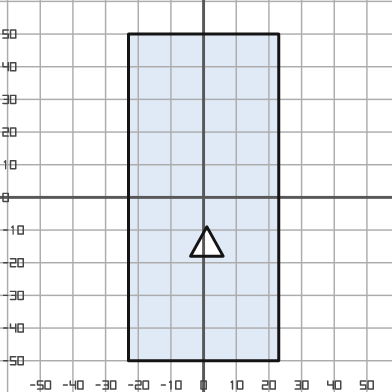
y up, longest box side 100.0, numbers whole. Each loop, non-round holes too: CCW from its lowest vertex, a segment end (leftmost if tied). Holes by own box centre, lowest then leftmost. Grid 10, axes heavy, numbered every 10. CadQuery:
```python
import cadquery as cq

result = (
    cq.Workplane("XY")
    .moveTo(-23.0, -50.0)
    .lineTo(23.0, -50.0)
    .lineTo(23.0, 50.0)
    .lineTo(-23.0, 50.0)
    .close()
    .moveTo(-4.0, -18.0)
    .lineTo(6.0, -18.0)
    .lineTo(1.0, -9.0)
    .close()
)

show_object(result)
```